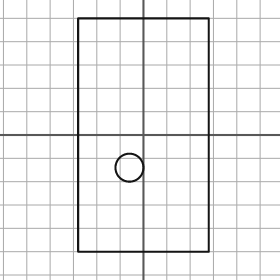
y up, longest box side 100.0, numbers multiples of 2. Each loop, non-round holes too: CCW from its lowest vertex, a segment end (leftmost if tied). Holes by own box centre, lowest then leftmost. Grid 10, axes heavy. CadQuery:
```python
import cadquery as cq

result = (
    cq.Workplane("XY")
    .moveTo(-28.0, -50.0)
    .lineTo(28.0, -50.0)
    .lineTo(28.0, 50.0)
    .lineTo(-28.0, 50.0)
    .close()
    .moveTo(-6.0, -14.0)
    .circle(6.0)
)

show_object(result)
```